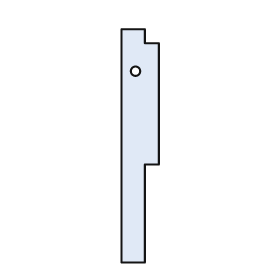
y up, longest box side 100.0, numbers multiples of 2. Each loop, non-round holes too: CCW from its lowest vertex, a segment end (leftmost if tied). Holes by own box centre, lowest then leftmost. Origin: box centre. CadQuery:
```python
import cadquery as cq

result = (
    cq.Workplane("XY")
    .moveTo(-8.0, -50.0)
    .lineTo(2.0, -50.0)
    .lineTo(2.0, -8.0)
    .lineTo(8.0, -8.0)
    .lineTo(8.0, 44.0)
    .lineTo(2.0, 44.0)
    .lineTo(2.0, 50.0)
    .lineTo(-8.0, 50.0)
    .close()
    .moveTo(-2.0, 32.0)
    .circle(2.0)
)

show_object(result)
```